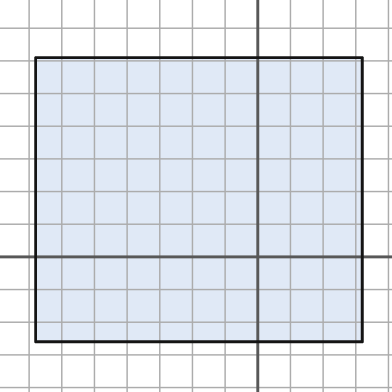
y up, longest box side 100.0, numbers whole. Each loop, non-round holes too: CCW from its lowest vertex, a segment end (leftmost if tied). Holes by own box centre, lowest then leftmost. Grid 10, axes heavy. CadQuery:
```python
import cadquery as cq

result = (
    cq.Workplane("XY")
    .moveTo(-68.0, -26.0)
    .lineTo(32.0, -26.0)
    .lineTo(32.0, 61.0)
    .lineTo(-68.0, 61.0)
    .close()
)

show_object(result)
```